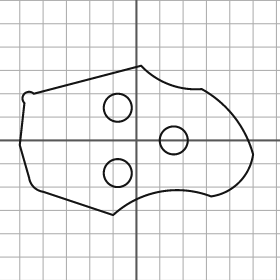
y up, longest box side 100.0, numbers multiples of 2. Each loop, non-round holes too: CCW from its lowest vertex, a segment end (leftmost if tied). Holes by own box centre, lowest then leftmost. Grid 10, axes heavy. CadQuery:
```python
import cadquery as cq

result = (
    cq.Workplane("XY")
    .moveTo(-10.0, -32.0)
    .threePointArc((10.0, -22.0), (32.0, -24.0))
    .threePointArc((44.0, -18.0), (50.0, -6.0))
    .threePointArc((42.0, 10.0), (28.0, 22.0))
    .threePointArc((14.0, 24.0), (2.0, 32.0))
    .lineTo(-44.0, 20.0)
    .threePointArc((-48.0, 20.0), (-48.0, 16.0))
    .lineTo(-50.0, -2.0)
    .lineTo(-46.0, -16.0)
    .threePointArc((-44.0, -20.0), (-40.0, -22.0))
    .close()
    .moveTo(-8.0, -14.0)
    .circle(6.0)
    .moveTo(16.0, 0.0)
    .circle(6.0)
    .moveTo(-8.0, 14.0)
    .circle(6.0)
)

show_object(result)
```